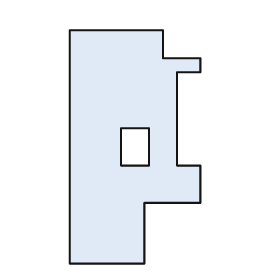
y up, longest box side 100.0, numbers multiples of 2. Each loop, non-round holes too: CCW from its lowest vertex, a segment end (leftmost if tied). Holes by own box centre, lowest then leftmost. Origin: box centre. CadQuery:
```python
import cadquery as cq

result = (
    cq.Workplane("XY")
    .moveTo(-28.0, -50.0)
    .lineTo(4.0, -50.0)
    .lineTo(4.0, -24.0)
    .lineTo(28.0, -24.0)
    .lineTo(28.0, -8.0)
    .lineTo(18.0, -8.0)
    .lineTo(18.0, 32.0)
    .lineTo(28.0, 32.0)
    .lineTo(28.0, 38.0)
    .lineTo(12.0, 38.0)
    .lineTo(12.0, 50.0)
    .lineTo(-28.0, 50.0)
    .close()
    .moveTo(-6.0, -8.0)
    .lineTo(6.0, -8.0)
    .lineTo(6.0, 8.0)
    .lineTo(-6.0, 8.0)
    .close()
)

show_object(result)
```